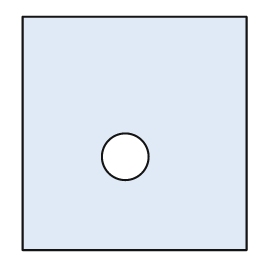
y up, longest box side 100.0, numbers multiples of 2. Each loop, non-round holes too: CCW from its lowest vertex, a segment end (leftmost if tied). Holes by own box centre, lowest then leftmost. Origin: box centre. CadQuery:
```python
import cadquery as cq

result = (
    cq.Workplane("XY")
    .moveTo(-48.0, -50.0)
    .lineTo(48.0, -50.0)
    .lineTo(48.0, 50.0)
    .lineTo(-48.0, 50.0)
    .close()
    .moveTo(-4.0, -10.0)
    .circle(10.0)
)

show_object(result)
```